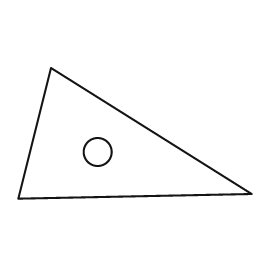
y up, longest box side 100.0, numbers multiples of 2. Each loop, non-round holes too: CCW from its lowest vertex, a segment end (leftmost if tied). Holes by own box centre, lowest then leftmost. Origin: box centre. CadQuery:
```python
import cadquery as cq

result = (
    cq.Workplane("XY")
    .moveTo(-50.0, -28.0)
    .lineTo(50.0, -26.0)
    .lineTo(-36.0, 28.0)
    .close()
    .moveTo(-16.0, -8.0)
    .circle(6.0)
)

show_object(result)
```